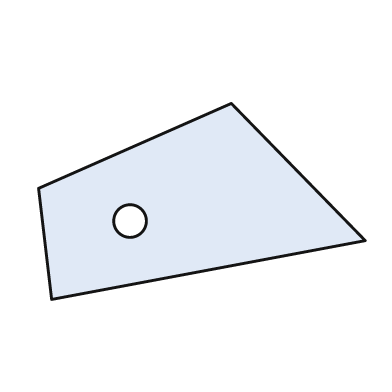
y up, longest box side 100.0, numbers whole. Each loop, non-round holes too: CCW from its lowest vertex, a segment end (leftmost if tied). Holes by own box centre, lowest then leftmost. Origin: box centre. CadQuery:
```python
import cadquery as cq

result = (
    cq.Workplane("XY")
    .moveTo(-46.0, -30.0)
    .lineTo(50.0, -12.0)
    .lineTo(9.0, 30.0)
    .lineTo(-50.0, 4.0)
    .close()
    .moveTo(-22.0, -6.0)
    .circle(5.0)
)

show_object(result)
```